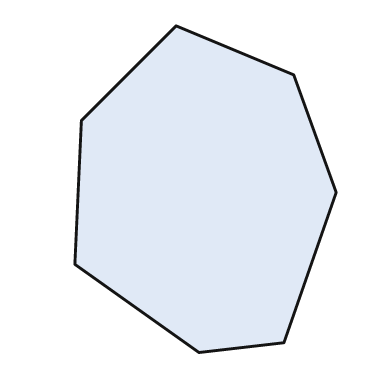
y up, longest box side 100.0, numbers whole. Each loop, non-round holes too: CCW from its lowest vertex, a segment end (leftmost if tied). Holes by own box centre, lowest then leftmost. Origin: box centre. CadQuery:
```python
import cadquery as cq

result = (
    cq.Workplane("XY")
    .moveTo(-2.0, -50.0)
    .lineTo(24.0, -47.0)
    .lineTo(40.0, -1.0)
    .lineTo(27.0, 35.0)
    .lineTo(-9.0, 50.0)
    .lineTo(-38.0, 21.0)
    .lineTo(-40.0, -23.0)
    .close()
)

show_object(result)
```